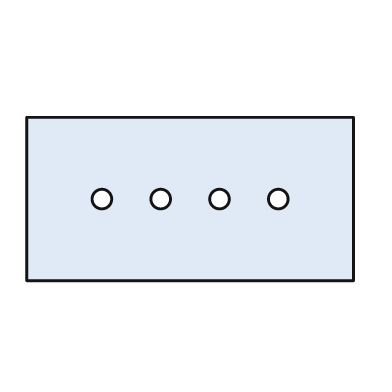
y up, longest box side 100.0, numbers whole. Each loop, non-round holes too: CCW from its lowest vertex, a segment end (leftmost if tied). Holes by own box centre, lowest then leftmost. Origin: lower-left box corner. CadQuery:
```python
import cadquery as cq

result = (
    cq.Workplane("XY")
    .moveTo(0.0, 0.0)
    .lineTo(100.0, 0.0)
    .lineTo(100.0, 50.0)
    .lineTo(0.0, 50.0)
    .close()
    .moveTo(23.0, 25.0)
    .circle(3.0)
    .moveTo(41.0, 25.0)
    .circle(3.0)
    .moveTo(59.0, 25.0)
    .circle(3.0)
    .moveTo(77.0, 25.0)
    .circle(3.0)
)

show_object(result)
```